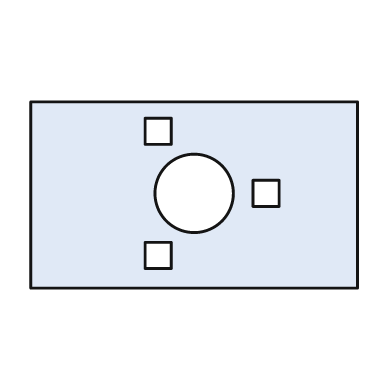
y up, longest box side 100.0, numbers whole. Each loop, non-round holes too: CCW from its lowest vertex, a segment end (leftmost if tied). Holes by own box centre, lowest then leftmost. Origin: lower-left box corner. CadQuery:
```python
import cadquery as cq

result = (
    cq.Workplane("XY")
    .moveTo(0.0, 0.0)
    .lineTo(100.0, 0.0)
    .lineTo(100.0, 57.0)
    .lineTo(0.0, 57.0)
    .close()
    .moveTo(35.0, 6.0)
    .lineTo(43.0, 6.0)
    .lineTo(43.0, 14.0)
    .lineTo(35.0, 14.0)
    .close()
    .moveTo(50.0, 29.0)
    .circle(12.0)
    .moveTo(68.0, 25.0)
    .lineTo(76.0, 25.0)
    .lineTo(76.0, 33.0)
    .lineTo(68.0, 33.0)
    .close()
    .moveTo(35.0, 44.0)
    .lineTo(43.0, 44.0)
    .lineTo(43.0, 52.0)
    .lineTo(35.0, 52.0)
    .close()
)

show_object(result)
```